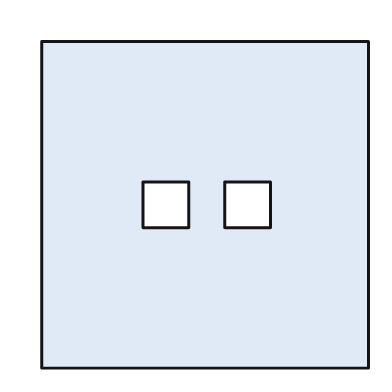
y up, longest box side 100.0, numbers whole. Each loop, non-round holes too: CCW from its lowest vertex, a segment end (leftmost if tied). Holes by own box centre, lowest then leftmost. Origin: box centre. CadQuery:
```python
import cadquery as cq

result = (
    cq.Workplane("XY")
    .moveTo(-50.0, -50.0)
    .lineTo(50.0, -50.0)
    .lineTo(50.0, 50.0)
    .lineTo(-50.0, 50.0)
    .close()
    .moveTo(-19.0, -7.0)
    .lineTo(-5.0, -7.0)
    .lineTo(-5.0, 7.0)
    .lineTo(-19.0, 7.0)
    .close()
    .moveTo(6.0, -7.0)
    .lineTo(20.0, -7.0)
    .lineTo(20.0, 7.0)
    .lineTo(6.0, 7.0)
    .close()
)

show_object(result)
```